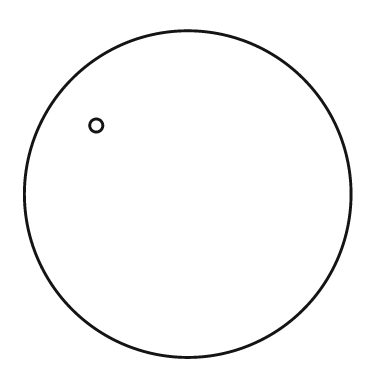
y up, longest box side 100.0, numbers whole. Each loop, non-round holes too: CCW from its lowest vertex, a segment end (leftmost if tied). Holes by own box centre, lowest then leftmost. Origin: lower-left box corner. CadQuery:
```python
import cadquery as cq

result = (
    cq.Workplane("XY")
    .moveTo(50.0, 50.0)
    .circle(50.0)
    .moveTo(22.0, 71.0)
    .circle(2.0)
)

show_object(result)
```